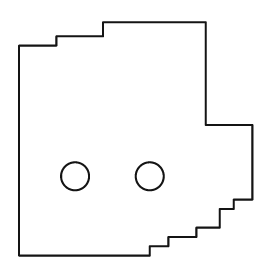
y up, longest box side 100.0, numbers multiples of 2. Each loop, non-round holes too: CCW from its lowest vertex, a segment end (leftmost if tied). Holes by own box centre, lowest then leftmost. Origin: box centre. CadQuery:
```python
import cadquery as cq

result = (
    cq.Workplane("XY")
    .moveTo(-50.0, -50.0)
    .lineTo(6.0, -50.0)
    .lineTo(6.0, -46.0)
    .lineTo(14.0, -46.0)
    .lineTo(14.0, -42.0)
    .lineTo(26.0, -42.0)
    .lineTo(26.0, -38.0)
    .lineTo(36.0, -38.0)
    .lineTo(36.0, -30.0)
    .lineTo(42.0, -30.0)
    .lineTo(42.0, -26.0)
    .lineTo(50.0, -26.0)
    .lineTo(50.0, 6.0)
    .lineTo(30.0, 6.0)
    .lineTo(30.0, 50.0)
    .lineTo(-14.0, 50.0)
    .lineTo(-14.0, 44.0)
    .lineTo(-34.0, 44.0)
    .lineTo(-34.0, 40.0)
    .lineTo(-50.0, 40.0)
    .close()
    .moveTo(-26.0, -16.0)
    .circle(6.0)
    .moveTo(6.0, -16.0)
    .circle(6.0)
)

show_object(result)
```